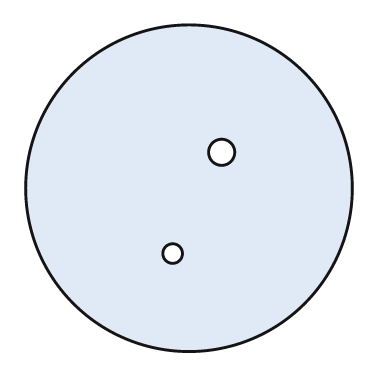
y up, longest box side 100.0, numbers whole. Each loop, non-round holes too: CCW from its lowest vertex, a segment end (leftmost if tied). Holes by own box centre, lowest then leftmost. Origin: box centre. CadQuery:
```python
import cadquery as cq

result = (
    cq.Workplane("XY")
    .moveTo(0.0, 0.0)
    .circle(50.0)
    .moveTo(-5.0, -20.0)
    .circle(3.0)
    .moveTo(10.0, 11.0)
    .circle(4.0)
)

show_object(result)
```